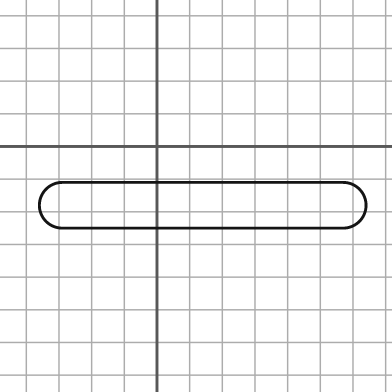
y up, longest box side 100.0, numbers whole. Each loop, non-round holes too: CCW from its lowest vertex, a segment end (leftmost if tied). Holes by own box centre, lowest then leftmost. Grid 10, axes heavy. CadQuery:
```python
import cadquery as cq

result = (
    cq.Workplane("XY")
    .moveTo(-29.0, -25.0)
    .lineTo(57.0, -25.0)
    .threePointArc((64.0, -18.0), (57.0, -11.0))
    .lineTo(-29.0, -11.0)
    .threePointArc((-36.0, -18.0), (-29.0, -25.0))
    .close()
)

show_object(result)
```